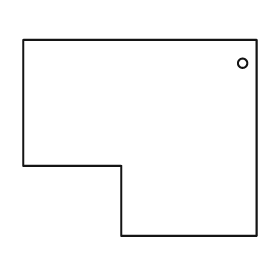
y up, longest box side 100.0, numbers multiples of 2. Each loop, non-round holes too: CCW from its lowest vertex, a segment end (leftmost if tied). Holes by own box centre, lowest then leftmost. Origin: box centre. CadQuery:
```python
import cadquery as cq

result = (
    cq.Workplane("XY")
    .moveTo(-8.0, -42.0)
    .lineTo(50.0, -42.0)
    .lineTo(50.0, 42.0)
    .lineTo(-50.0, 42.0)
    .lineTo(-50.0, -12.0)
    .lineTo(-8.0, -12.0)
    .close()
    .moveTo(44.0, 32.0)
    .circle(2.0)
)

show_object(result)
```